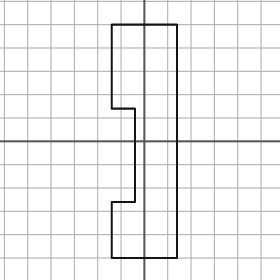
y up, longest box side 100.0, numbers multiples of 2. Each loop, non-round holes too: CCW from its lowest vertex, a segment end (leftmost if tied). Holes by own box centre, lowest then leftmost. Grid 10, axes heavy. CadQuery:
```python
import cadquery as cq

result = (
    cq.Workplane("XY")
    .moveTo(-14.0, -50.0)
    .lineTo(14.0, -50.0)
    .lineTo(14.0, 50.0)
    .lineTo(-14.0, 50.0)
    .lineTo(-14.0, 14.0)
    .lineTo(-4.0, 14.0)
    .lineTo(-4.0, -26.0)
    .lineTo(-14.0, -26.0)
    .close()
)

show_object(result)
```